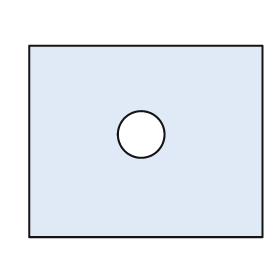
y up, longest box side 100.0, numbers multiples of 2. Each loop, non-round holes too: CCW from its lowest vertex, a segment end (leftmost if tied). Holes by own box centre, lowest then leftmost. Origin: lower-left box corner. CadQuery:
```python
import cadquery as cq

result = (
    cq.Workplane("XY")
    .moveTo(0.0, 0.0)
    .lineTo(100.0, 0.0)
    .lineTo(100.0, 82.0)
    .lineTo(0.0, 82.0)
    .close()
    .moveTo(48.0, 44.0)
    .circle(10.0)
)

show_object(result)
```